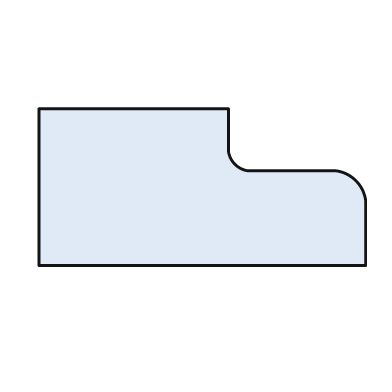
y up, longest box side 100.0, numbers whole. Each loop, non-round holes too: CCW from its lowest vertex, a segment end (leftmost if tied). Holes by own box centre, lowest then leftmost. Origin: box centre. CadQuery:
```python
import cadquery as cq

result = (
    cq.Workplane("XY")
    .moveTo(-50.0, -24.0)
    .lineTo(50.0, -24.0)
    .lineTo(50.0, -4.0)
    .threePointArc((47.0, 2.0), (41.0, 5.0))
    .lineTo(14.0, 5.0)
    .threePointArc((10.0, 7.0), (8.0, 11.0))
    .lineTo(8.0, 24.0)
    .lineTo(-50.0, 24.0)
    .close()
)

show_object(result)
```